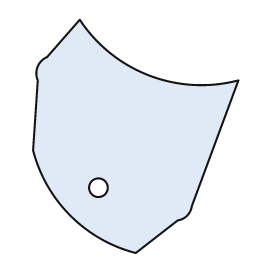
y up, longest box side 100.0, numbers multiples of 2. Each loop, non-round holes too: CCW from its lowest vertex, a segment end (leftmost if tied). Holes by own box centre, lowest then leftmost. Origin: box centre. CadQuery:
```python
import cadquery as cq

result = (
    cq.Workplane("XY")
    .moveTo(0.0, -50.0)
    .lineTo(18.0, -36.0)
    .threePointArc((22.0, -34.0), (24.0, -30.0))
    .lineTo(44.0, 24.0)
    .threePointArc((6.0, 26.0), (-24.0, 50.0))
    .lineTo(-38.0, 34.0)
    .threePointArc((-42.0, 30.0), (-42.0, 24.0))
    .lineTo(-44.0, -6.0)
    .threePointArc((-28.0, -34.0), (0.0, -50.0))
    .close()
    .moveTo(-16.0, -22.0)
    .circle(4.0)
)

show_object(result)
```